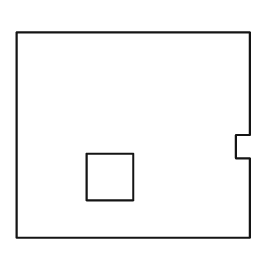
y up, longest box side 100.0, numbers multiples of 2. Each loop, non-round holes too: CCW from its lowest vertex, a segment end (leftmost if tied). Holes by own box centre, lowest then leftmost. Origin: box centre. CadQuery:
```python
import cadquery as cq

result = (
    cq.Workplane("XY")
    .moveTo(-50.0, -44.0)
    .lineTo(50.0, -44.0)
    .lineTo(50.0, -10.0)
    .lineTo(44.0, -10.0)
    .lineTo(44.0, 0.0)
    .lineTo(50.0, 0.0)
    .lineTo(50.0, 44.0)
    .lineTo(-50.0, 44.0)
    .close()
    .moveTo(-20.0, -28.0)
    .lineTo(0.0, -28.0)
    .lineTo(0.0, -8.0)
    .lineTo(-20.0, -8.0)
    .close()
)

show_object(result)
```